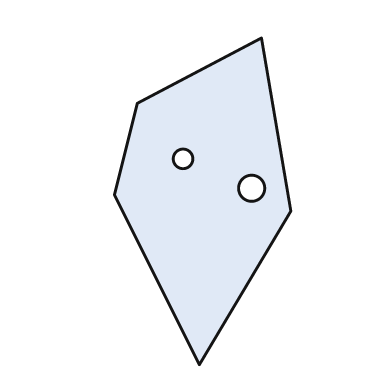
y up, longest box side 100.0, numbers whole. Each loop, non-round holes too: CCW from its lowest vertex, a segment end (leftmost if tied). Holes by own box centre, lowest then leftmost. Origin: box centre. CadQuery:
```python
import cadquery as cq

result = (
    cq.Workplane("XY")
    .moveTo(-1.0, -50.0)
    .lineTo(27.0, -3.0)
    .lineTo(18.0, 50.0)
    .lineTo(-20.0, 30.0)
    .lineTo(-27.0, 2.0)
    .close()
    .moveTo(15.0, 4.0)
    .circle(4.0)
    .moveTo(-6.0, 13.0)
    .circle(3.0)
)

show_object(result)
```